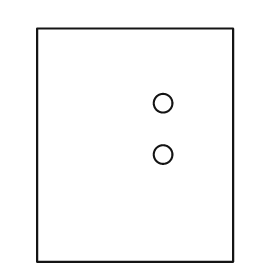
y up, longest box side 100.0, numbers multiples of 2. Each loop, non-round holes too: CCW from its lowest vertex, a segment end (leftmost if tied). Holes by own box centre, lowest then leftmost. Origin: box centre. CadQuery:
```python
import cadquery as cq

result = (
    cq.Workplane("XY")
    .moveTo(-42.0, -50.0)
    .lineTo(42.0, -50.0)
    .lineTo(42.0, 50.0)
    .lineTo(-42.0, 50.0)
    .close()
    .moveTo(12.0, -4.0)
    .circle(4.0)
    .moveTo(12.0, 18.0)
    .circle(4.0)
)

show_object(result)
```